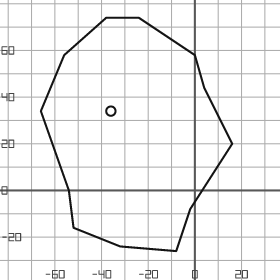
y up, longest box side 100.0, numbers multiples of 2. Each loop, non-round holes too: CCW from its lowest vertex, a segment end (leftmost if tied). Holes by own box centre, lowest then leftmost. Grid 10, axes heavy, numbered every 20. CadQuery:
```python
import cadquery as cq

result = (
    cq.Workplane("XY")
    .moveTo(-8.0, -26.0)
    .lineTo(-2.0, -8.0)
    .lineTo(16.0, 20.0)
    .lineTo(4.0, 44.0)
    .lineTo(0.0, 58.0)
    .lineTo(-24.0, 74.0)
    .lineTo(-38.0, 74.0)
    .lineTo(-56.0, 58.0)
    .lineTo(-66.0, 34.0)
    .lineTo(-54.0, 0.0)
    .lineTo(-52.0, -16.0)
    .lineTo(-32.0, -24.0)
    .close()
    .moveTo(-36.0, 34.0)
    .circle(2.0)
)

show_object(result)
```